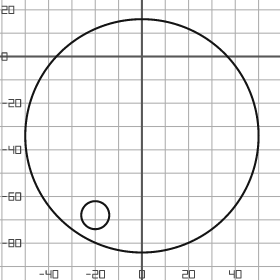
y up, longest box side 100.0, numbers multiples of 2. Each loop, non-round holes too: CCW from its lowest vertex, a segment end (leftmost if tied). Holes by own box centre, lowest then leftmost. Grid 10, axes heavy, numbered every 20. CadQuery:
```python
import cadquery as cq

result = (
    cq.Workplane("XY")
    .moveTo(0.0, -34.0)
    .circle(50.0)
    .moveTo(-20.0, -68.0)
    .circle(6.0)
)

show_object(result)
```